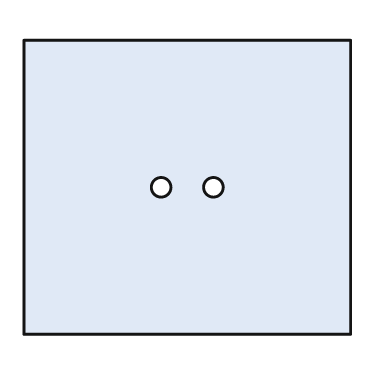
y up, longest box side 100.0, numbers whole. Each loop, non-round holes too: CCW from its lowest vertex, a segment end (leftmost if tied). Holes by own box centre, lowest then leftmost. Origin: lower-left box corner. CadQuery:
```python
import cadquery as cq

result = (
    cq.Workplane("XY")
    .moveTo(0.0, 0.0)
    .lineTo(100.0, 0.0)
    .lineTo(100.0, 90.0)
    .lineTo(0.0, 90.0)
    .close()
    .moveTo(42.0, 45.0)
    .circle(3.0)
    .moveTo(58.0, 45.0)
    .circle(3.0)
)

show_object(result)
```